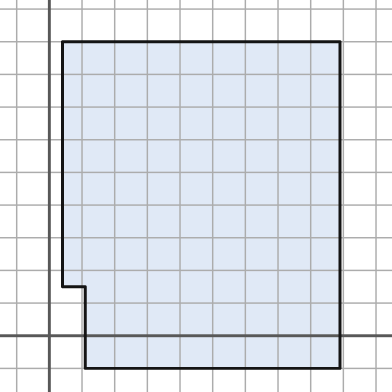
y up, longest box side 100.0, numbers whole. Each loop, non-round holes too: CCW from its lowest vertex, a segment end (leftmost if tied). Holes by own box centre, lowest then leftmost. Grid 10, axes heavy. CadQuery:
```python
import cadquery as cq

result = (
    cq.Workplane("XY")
    .moveTo(11.0, -10.0)
    .lineTo(89.0, -10.0)
    .lineTo(89.0, 90.0)
    .lineTo(4.0, 90.0)
    .lineTo(4.0, 15.0)
    .lineTo(11.0, 15.0)
    .close()
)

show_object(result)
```